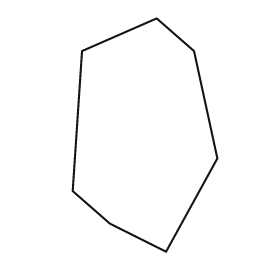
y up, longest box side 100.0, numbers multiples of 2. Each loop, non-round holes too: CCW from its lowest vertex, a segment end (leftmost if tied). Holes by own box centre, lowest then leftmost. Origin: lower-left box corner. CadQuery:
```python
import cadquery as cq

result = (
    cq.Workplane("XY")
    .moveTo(40.0, 0.0)
    .lineTo(62.0, 40.0)
    .lineTo(52.0, 86.0)
    .lineTo(36.0, 100.0)
    .lineTo(4.0, 86.0)
    .lineTo(0.0, 26.0)
    .lineTo(16.0, 12.0)
    .close()
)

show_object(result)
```